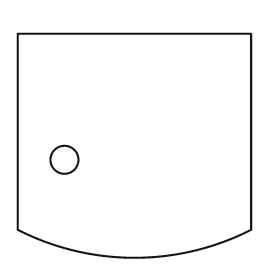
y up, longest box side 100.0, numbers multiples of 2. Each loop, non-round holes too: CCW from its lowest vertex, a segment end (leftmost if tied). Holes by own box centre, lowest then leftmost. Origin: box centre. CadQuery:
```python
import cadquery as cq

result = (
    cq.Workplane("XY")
    .moveTo(-50.0, -36.0)
    .threePointArc((0.0, -48.0), (50.0, -36.0))
    .lineTo(50.0, 48.0)
    .lineTo(-50.0, 48.0)
    .close()
    .moveTo(-30.0, -6.0)
    .circle(6.0)
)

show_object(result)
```